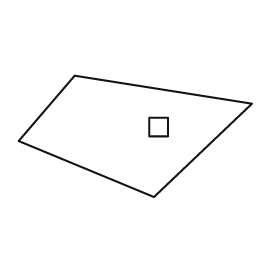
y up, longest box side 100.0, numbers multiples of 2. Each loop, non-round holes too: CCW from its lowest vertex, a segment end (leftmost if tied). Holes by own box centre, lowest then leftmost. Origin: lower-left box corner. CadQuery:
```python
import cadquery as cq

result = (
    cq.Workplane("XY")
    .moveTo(58.0, 0.0)
    .lineTo(100.0, 40.0)
    .lineTo(24.0, 52.0)
    .lineTo(0.0, 24.0)
    .close()
    .moveTo(56.0, 26.0)
    .lineTo(64.0, 26.0)
    .lineTo(64.0, 34.0)
    .lineTo(56.0, 34.0)
    .close()
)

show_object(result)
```